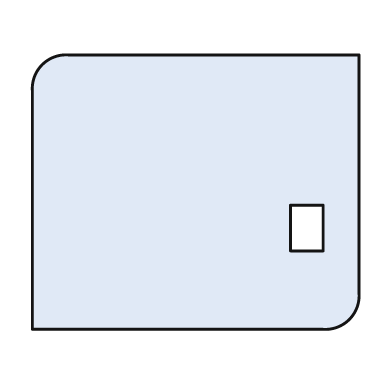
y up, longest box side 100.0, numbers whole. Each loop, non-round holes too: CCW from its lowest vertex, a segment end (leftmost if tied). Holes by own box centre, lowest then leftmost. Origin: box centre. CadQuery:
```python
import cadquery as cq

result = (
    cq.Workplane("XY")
    .moveTo(-50.0, -42.0)
    .lineTo(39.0, -42.0)
    .threePointArc((47.0, -39.0), (50.0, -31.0))
    .lineTo(50.0, 42.0)
    .lineTo(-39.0, 42.0)
    .threePointArc((-47.0, 39.0), (-50.0, 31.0))
    .close()
    .moveTo(29.0, -18.0)
    .lineTo(39.0, -18.0)
    .lineTo(39.0, -4.0)
    .lineTo(29.0, -4.0)
    .close()
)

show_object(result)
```